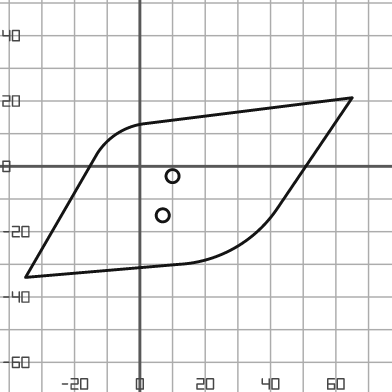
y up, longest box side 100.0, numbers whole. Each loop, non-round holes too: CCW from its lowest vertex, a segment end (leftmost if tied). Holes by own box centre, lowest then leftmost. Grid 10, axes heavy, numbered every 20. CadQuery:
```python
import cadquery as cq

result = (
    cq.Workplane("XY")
    .moveTo(-35.0, -34.0)
    .lineTo(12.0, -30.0)
    .threePointArc((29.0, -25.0), (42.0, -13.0))
    .lineTo(65.0, 21.0)
    .lineTo(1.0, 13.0)
    .threePointArc((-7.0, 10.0), (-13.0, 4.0))
    .close()
    .moveTo(7.0, -15.0)
    .circle(2.0)
    .moveTo(10.0, -3.0)
    .circle(2.0)
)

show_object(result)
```